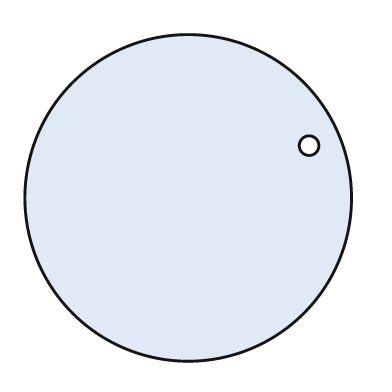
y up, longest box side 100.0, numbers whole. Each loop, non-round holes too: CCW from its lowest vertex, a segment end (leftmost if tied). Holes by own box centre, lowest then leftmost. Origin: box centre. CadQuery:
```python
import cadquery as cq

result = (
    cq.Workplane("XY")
    .moveTo(0.0, 0.0)
    .circle(50.0)
    .moveTo(37.0, 16.0)
    .circle(3.0)
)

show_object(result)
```